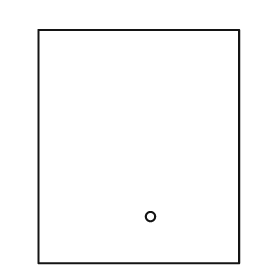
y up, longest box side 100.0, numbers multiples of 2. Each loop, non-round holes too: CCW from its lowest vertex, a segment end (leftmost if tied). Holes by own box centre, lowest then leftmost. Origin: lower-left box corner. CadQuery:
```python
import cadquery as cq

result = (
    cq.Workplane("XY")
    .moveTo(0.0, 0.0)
    .lineTo(86.0, 0.0)
    .lineTo(86.0, 100.0)
    .lineTo(0.0, 100.0)
    .close()
    .moveTo(48.0, 20.0)
    .circle(2.0)
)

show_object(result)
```